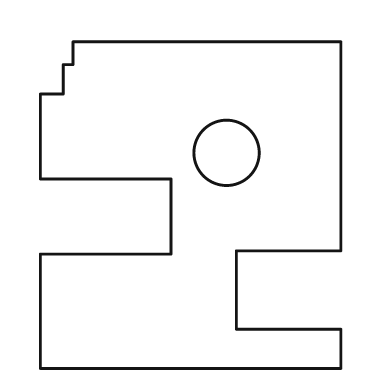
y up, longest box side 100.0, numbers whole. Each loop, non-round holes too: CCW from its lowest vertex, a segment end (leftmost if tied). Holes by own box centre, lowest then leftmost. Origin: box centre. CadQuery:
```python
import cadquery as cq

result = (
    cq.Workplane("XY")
    .moveTo(-46.0, -50.0)
    .lineTo(46.0, -50.0)
    .lineTo(46.0, -38.0)
    .lineTo(14.0, -38.0)
    .lineTo(14.0, -14.0)
    .lineTo(46.0, -14.0)
    .lineTo(46.0, 50.0)
    .lineTo(-36.0, 50.0)
    .lineTo(-36.0, 43.0)
    .lineTo(-39.0, 43.0)
    .lineTo(-39.0, 34.0)
    .lineTo(-46.0, 34.0)
    .lineTo(-46.0, 8.0)
    .lineTo(-6.0, 8.0)
    .lineTo(-6.0, -15.0)
    .lineTo(-46.0, -15.0)
    .close()
    .moveTo(11.0, 16.0)
    .circle(10.0)
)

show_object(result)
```